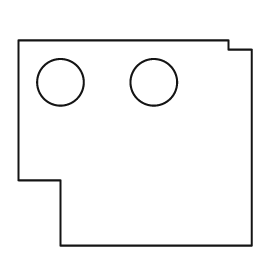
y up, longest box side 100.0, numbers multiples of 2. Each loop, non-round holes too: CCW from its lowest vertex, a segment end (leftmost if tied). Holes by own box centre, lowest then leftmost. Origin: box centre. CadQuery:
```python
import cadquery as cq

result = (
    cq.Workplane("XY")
    .moveTo(-32.0, -44.0)
    .lineTo(50.0, -44.0)
    .lineTo(50.0, 40.0)
    .lineTo(40.0, 40.0)
    .lineTo(40.0, 44.0)
    .lineTo(-50.0, 44.0)
    .lineTo(-50.0, -16.0)
    .lineTo(-32.0, -16.0)
    .close()
    .moveTo(-32.0, 26.0)
    .circle(10.0)
    .moveTo(8.0, 26.0)
    .circle(10.0)
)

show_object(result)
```